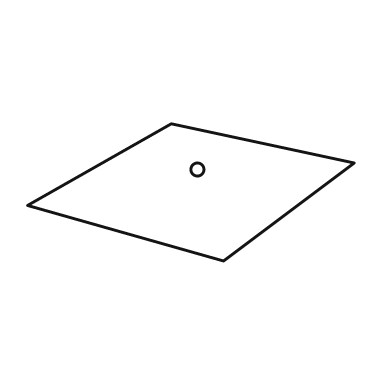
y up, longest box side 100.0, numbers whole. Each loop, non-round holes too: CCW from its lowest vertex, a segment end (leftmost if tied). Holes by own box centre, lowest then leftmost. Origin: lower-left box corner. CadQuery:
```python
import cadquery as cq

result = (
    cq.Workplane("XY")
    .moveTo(60.0, 0.0)
    .lineTo(100.0, 30.0)
    .lineTo(44.0, 42.0)
    .lineTo(0.0, 17.0)
    .close()
    .moveTo(52.0, 28.0)
    .circle(2.0)
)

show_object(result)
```